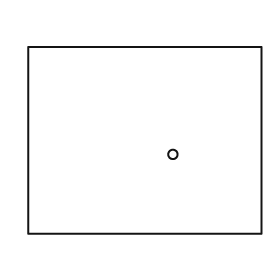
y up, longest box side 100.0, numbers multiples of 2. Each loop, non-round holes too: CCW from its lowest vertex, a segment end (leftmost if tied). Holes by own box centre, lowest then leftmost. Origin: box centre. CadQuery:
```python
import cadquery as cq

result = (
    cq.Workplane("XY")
    .moveTo(-50.0, -40.0)
    .lineTo(50.0, -40.0)
    .lineTo(50.0, 40.0)
    .lineTo(-50.0, 40.0)
    .close()
    .moveTo(12.0, -6.0)
    .circle(2.0)
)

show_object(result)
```